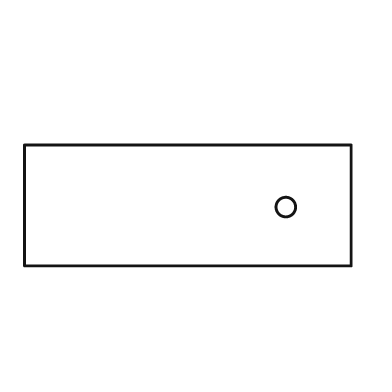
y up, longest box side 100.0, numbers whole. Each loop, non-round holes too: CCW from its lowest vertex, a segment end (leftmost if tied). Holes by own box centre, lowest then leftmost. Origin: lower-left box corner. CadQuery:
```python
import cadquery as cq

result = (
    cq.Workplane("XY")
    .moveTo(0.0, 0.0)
    .lineTo(100.0, 0.0)
    .lineTo(100.0, 37.0)
    .lineTo(0.0, 37.0)
    .close()
    .moveTo(80.0, 18.0)
    .circle(3.0)
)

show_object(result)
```